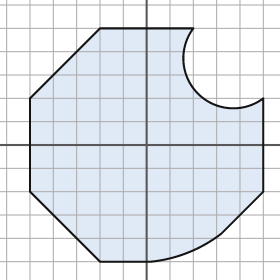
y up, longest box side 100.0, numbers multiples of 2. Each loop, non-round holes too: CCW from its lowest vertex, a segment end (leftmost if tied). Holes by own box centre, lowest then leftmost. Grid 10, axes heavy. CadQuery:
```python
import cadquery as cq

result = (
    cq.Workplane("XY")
    .moveTo(-20.0, -50.0)
    .lineTo(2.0, -50.0)
    .threePointArc((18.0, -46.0), (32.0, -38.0))
    .lineTo(50.0, -20.0)
    .lineTo(50.0, 20.0)
    .threePointArc((22.0, 22.0), (20.0, 50.0))
    .lineTo(-20.0, 50.0)
    .lineTo(-50.0, 20.0)
    .lineTo(-50.0, -20.0)
    .close()
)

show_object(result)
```